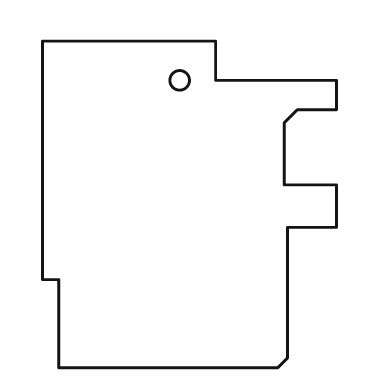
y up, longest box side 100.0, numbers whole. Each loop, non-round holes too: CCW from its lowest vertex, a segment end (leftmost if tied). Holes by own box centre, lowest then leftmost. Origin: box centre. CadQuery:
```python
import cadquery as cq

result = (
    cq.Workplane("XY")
    .moveTo(-40.0, -50.0)
    .lineTo(27.0, -50.0)
    .lineTo(30.0, -47.0)
    .lineTo(30.0, -7.0)
    .lineTo(45.0, -7.0)
    .lineTo(45.0, 6.0)
    .lineTo(29.0, 6.0)
    .lineTo(29.0, 25.0)
    .lineTo(33.0, 29.0)
    .lineTo(45.0, 29.0)
    .lineTo(45.0, 38.0)
    .lineTo(8.0, 38.0)
    .lineTo(8.0, 50.0)
    .lineTo(-45.0, 50.0)
    .lineTo(-45.0, -23.0)
    .lineTo(-40.0, -23.0)
    .close()
    .moveTo(-3.0, 38.0)
    .circle(3.0)
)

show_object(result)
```